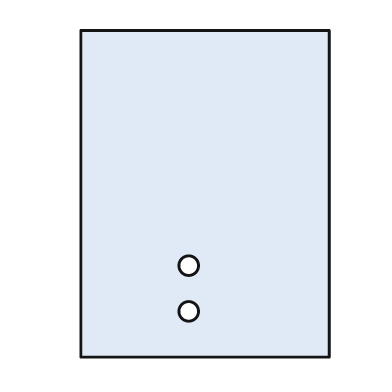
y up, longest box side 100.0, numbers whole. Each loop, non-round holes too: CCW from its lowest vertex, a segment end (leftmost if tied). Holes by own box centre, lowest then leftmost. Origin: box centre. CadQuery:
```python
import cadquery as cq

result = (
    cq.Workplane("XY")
    .moveTo(-38.0, -50.0)
    .lineTo(38.0, -50.0)
    .lineTo(38.0, 50.0)
    .lineTo(-38.0, 50.0)
    .close()
    .moveTo(-5.0, -36.0)
    .circle(3.0)
    .moveTo(-5.0, -22.0)
    .circle(3.0)
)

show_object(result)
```